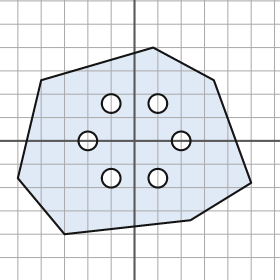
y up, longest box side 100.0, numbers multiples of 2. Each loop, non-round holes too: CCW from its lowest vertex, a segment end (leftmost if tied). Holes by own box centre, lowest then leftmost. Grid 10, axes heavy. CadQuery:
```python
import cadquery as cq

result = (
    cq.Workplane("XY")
    .moveTo(-30.0, -40.0)
    .lineTo(24.0, -34.0)
    .lineTo(50.0, -18.0)
    .lineTo(34.0, 26.0)
    .lineTo(8.0, 40.0)
    .lineTo(-40.0, 26.0)
    .lineTo(-50.0, -16.0)
    .close()
    .moveTo(-10.0, -16.0)
    .circle(4.0)
    .moveTo(10.0, -16.0)
    .circle(4.0)
    .moveTo(-20.0, 0.0)
    .circle(4.0)
    .moveTo(20.0, 0.0)
    .circle(4.0)
    .moveTo(-10.0, 16.0)
    .circle(4.0)
    .moveTo(10.0, 16.0)
    .circle(4.0)
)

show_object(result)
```